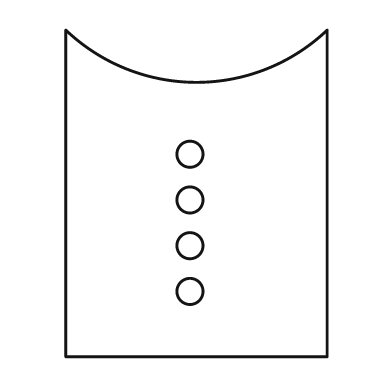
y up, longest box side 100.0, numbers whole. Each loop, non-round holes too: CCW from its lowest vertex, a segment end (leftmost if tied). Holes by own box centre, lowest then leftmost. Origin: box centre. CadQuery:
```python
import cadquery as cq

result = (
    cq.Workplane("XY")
    .moveTo(-40.0, -50.0)
    .lineTo(40.0, -50.0)
    .lineTo(40.0, 50.0)
    .threePointArc((0.0, 34.0), (-40.0, 50.0))
    .close()
    .moveTo(-2.0, -30.0)
    .circle(4.0)
    .moveTo(-2.0, -16.0)
    .circle(4.0)
    .moveTo(-2.0, -2.0)
    .circle(4.0)
    .moveTo(-2.0, 12.0)
    .circle(4.0)
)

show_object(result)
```